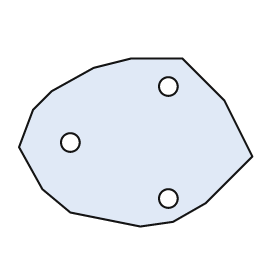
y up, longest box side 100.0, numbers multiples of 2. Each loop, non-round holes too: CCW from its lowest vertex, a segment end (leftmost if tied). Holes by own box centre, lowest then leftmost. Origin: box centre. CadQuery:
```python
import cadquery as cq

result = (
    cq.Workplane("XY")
    .moveTo(2.0, -36.0)
    .lineTo(16.0, -34.0)
    .lineTo(30.0, -26.0)
    .lineTo(50.0, -6.0)
    .lineTo(38.0, 18.0)
    .lineTo(20.0, 36.0)
    .lineTo(-2.0, 36.0)
    .lineTo(-18.0, 32.0)
    .lineTo(-36.0, 22.0)
    .lineTo(-44.0, 14.0)
    .lineTo(-50.0, -2.0)
    .lineTo(-40.0, -20.0)
    .lineTo(-28.0, -30.0)
    .close()
    .moveTo(14.0, -24.0)
    .circle(4.0)
    .moveTo(-28.0, 0.0)
    .circle(4.0)
    .moveTo(14.0, 24.0)
    .circle(4.0)
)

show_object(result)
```